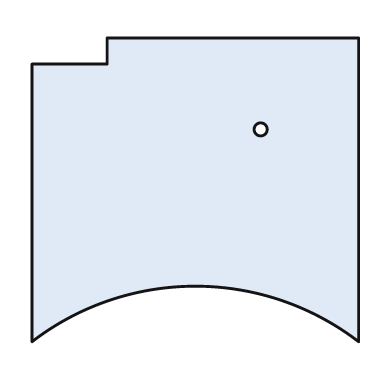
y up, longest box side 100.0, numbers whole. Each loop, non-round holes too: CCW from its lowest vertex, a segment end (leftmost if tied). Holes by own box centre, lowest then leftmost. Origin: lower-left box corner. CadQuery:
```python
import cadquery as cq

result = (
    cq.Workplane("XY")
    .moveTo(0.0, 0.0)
    .threePointArc((50.0, 17.0), (100.0, 0.0))
    .lineTo(100.0, 93.0)
    .lineTo(23.0, 93.0)
    .lineTo(23.0, 85.0)
    .lineTo(0.0, 85.0)
    .close()
    .moveTo(70.0, 65.0)
    .circle(2.0)
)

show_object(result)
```